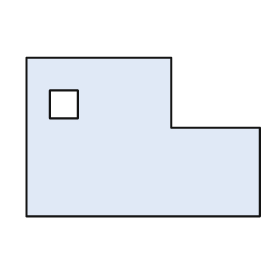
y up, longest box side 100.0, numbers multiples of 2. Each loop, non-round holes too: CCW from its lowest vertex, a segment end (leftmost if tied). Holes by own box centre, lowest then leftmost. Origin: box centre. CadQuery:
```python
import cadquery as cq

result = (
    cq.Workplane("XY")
    .moveTo(-50.0, -34.0)
    .lineTo(50.0, -34.0)
    .lineTo(50.0, 4.0)
    .lineTo(12.0, 4.0)
    .lineTo(12.0, 34.0)
    .lineTo(-50.0, 34.0)
    .close()
    .moveTo(-40.0, 8.0)
    .lineTo(-28.0, 8.0)
    .lineTo(-28.0, 20.0)
    .lineTo(-40.0, 20.0)
    .close()
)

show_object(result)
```